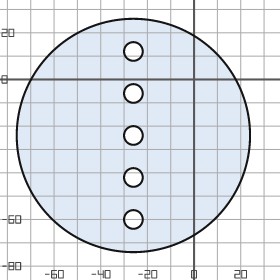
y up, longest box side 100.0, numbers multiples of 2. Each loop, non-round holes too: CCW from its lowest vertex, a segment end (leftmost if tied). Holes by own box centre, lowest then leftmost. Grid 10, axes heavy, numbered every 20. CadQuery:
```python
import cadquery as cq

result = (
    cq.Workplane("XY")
    .moveTo(-26.0, -24.0)
    .circle(50.0)
    .moveTo(-26.0, -60.0)
    .circle(4.0)
    .moveTo(-26.0, -42.0)
    .circle(4.0)
    .moveTo(-26.0, -24.0)
    .circle(4.0)
    .moveTo(-26.0, -6.0)
    .circle(4.0)
    .moveTo(-26.0, 12.0)
    .circle(4.0)
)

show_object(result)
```